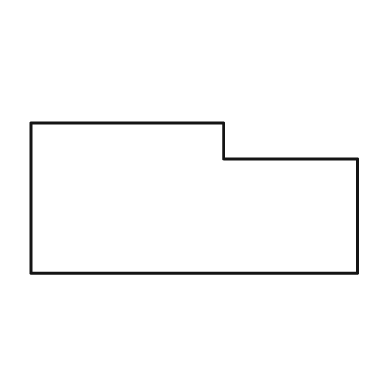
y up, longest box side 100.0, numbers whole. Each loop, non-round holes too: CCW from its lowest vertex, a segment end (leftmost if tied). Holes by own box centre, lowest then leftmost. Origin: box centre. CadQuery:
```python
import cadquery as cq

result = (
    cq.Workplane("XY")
    .moveTo(-50.0, -23.0)
    .lineTo(50.0, -23.0)
    .lineTo(50.0, 12.0)
    .lineTo(9.0, 12.0)
    .lineTo(9.0, 23.0)
    .lineTo(-50.0, 23.0)
    .close()
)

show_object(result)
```